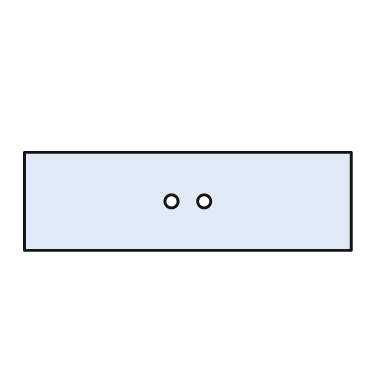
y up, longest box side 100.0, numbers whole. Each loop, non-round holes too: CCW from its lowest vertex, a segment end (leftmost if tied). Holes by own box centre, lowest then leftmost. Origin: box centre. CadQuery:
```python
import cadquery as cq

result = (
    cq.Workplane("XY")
    .moveTo(-50.0, -15.0)
    .lineTo(50.0, -15.0)
    .lineTo(50.0, 15.0)
    .lineTo(-50.0, 15.0)
    .close()
    .moveTo(-5.0, 0.0)
    .circle(2.0)
    .moveTo(5.0, 0.0)
    .circle(2.0)
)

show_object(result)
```